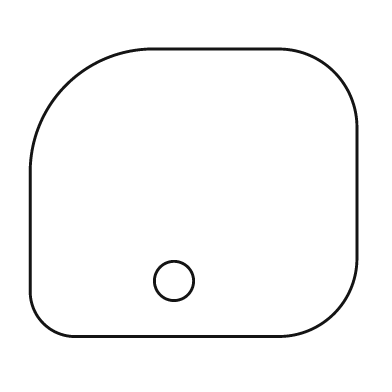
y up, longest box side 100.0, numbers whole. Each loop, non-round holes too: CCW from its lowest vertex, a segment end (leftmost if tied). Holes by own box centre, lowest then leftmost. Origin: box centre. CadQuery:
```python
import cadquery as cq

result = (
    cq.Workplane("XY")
    .moveTo(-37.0, -44.0)
    .lineTo(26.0, -44.0)
    .threePointArc((43.0, -37.0), (50.0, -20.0))
    .lineTo(50.0, 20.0)
    .threePointArc((43.0, 37.0), (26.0, 44.0))
    .lineTo(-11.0, 44.0)
    .threePointArc((-39.0, 33.0), (-50.0, 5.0))
    .lineTo(-50.0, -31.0)
    .threePointArc((-46.0, -40.0), (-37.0, -44.0))
    .close()
    .moveTo(-6.0, -27.0)
    .circle(6.0)
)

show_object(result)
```